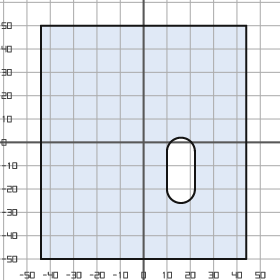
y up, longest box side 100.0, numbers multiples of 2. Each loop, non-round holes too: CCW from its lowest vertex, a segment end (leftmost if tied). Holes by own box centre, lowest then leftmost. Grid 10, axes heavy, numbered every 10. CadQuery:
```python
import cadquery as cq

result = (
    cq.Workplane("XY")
    .moveTo(-44.0, -50.0)
    .lineTo(44.0, -50.0)
    .lineTo(44.0, 50.0)
    .lineTo(-44.0, 50.0)
    .close()
    .moveTo(10.0, -20.0)
    .threePointArc((16.0, -26.0), (22.0, -20.0))
    .lineTo(22.0, -4.0)
    .threePointArc((16.0, 2.0), (10.0, -4.0))
    .close()
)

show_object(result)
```